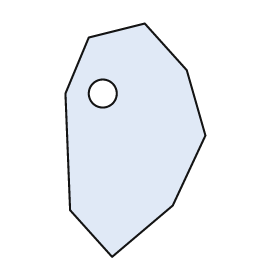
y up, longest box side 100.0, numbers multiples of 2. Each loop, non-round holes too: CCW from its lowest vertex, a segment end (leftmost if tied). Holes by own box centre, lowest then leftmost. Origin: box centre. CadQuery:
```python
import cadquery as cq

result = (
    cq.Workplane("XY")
    .moveTo(-10.0, -50.0)
    .lineTo(16.0, -28.0)
    .lineTo(30.0, 2.0)
    .lineTo(22.0, 30.0)
    .lineTo(4.0, 50.0)
    .lineTo(-20.0, 44.0)
    .lineTo(-30.0, 20.0)
    .lineTo(-28.0, -30.0)
    .close()
    .moveTo(-14.0, 20.0)
    .circle(6.0)
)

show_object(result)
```